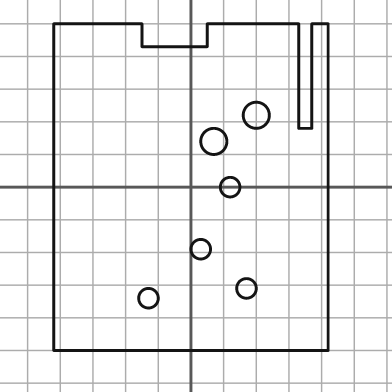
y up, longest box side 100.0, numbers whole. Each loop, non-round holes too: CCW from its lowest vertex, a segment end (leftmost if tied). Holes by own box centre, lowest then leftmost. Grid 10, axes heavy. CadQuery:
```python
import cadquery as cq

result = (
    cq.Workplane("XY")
    .moveTo(-42.0, -50.0)
    .lineTo(42.0, -50.0)
    .lineTo(42.0, 50.0)
    .lineTo(37.0, 50.0)
    .lineTo(37.0, 18.0)
    .lineTo(33.0, 18.0)
    .lineTo(33.0, 50.0)
    .lineTo(5.0, 50.0)
    .lineTo(5.0, 43.0)
    .lineTo(-15.0, 43.0)
    .lineTo(-15.0, 50.0)
    .lineTo(-42.0, 50.0)
    .close()
    .moveTo(-13.0, -34.0)
    .circle(3.0)
    .moveTo(17.0, -31.0)
    .circle(3.0)
    .moveTo(3.0, -19.0)
    .circle(3.0)
    .moveTo(12.0, 0.0)
    .circle(3.0)
    .moveTo(7.0, 14.0)
    .circle(4.0)
    .moveTo(20.0, 22.0)
    .circle(4.0)
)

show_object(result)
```